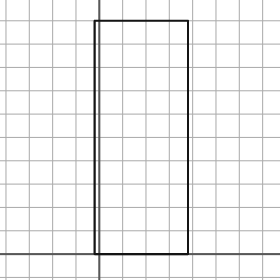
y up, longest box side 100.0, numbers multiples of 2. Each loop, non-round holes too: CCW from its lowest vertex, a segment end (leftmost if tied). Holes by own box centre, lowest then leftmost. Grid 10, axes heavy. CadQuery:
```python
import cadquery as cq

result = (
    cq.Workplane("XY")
    .moveTo(-2.0, 0.0)
    .lineTo(38.0, 0.0)
    .lineTo(38.0, 100.0)
    .lineTo(-2.0, 100.0)
    .close()
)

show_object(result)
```